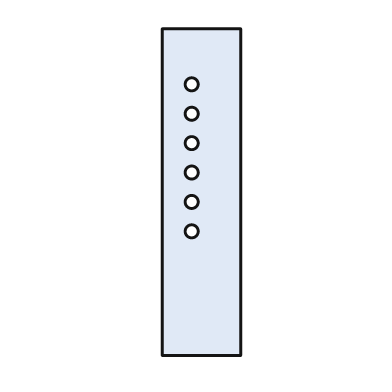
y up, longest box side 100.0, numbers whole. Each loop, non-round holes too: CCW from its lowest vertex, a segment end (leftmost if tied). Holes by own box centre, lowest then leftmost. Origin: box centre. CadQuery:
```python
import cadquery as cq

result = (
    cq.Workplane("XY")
    .moveTo(-12.0, -50.0)
    .lineTo(12.0, -50.0)
    .lineTo(12.0, 50.0)
    .lineTo(-12.0, 50.0)
    .close()
    .moveTo(-3.0, -12.0)
    .circle(2.0)
    .moveTo(-3.0, -3.0)
    .circle(2.0)
    .moveTo(-3.0, 6.0)
    .circle(2.0)
    .moveTo(-3.0, 15.0)
    .circle(2.0)
    .moveTo(-3.0, 24.0)
    .circle(2.0)
    .moveTo(-3.0, 33.0)
    .circle(2.0)
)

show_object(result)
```